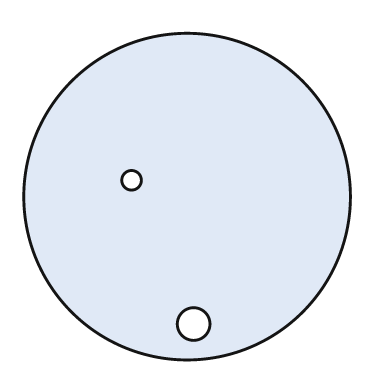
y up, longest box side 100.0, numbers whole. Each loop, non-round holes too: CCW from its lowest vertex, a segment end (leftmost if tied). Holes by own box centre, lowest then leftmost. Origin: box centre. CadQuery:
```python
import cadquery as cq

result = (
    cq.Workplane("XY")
    .moveTo(0.0, 0.0)
    .circle(50.0)
    .moveTo(2.0, -39.0)
    .circle(5.0)
    .moveTo(-17.0, 5.0)
    .circle(3.0)
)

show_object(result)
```